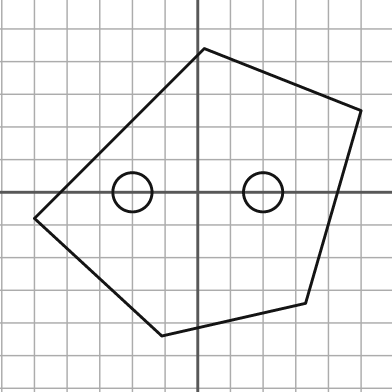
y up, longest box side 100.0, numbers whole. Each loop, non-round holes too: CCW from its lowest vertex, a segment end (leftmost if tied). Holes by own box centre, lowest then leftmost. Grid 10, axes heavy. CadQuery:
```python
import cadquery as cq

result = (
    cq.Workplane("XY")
    .moveTo(-11.0, -44.0)
    .lineTo(33.0, -34.0)
    .lineTo(50.0, 25.0)
    .lineTo(2.0, 44.0)
    .lineTo(-50.0, -8.0)
    .close()
    .moveTo(-20.0, 0.0)
    .circle(6.0)
    .moveTo(20.0, 0.0)
    .circle(6.0)
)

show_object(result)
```